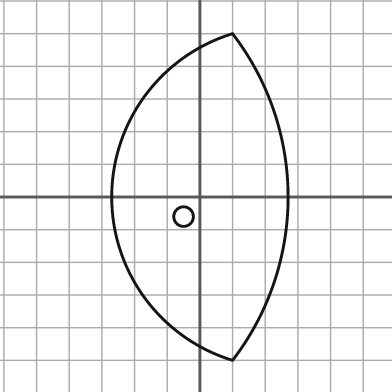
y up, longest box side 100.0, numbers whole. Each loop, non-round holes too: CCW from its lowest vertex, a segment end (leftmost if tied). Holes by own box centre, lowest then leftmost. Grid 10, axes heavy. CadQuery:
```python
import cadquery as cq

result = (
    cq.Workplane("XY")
    .moveTo(10.0, -50.0)
    .threePointArc((27.0, 0.0), (10.0, 50.0))
    .threePointArc((-27.0, 0.0), (10.0, -50.0))
    .close()
    .moveTo(-5.0, -6.0)
    .circle(3.0)
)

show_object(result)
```